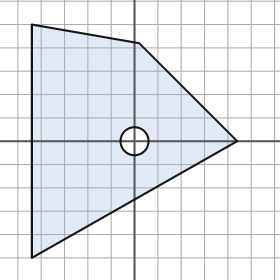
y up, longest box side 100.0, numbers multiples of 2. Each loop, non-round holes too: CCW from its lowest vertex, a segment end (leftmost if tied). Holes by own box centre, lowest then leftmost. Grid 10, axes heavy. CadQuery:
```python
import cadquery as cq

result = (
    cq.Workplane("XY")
    .moveTo(-44.0, -50.0)
    .lineTo(44.0, 0.0)
    .lineTo(2.0, 42.0)
    .lineTo(-44.0, 50.0)
    .close()
    .moveTo(0.0, 0.0)
    .circle(6.0)
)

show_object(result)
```